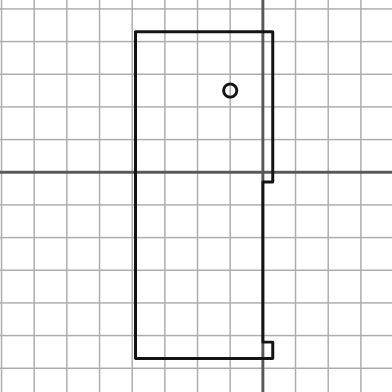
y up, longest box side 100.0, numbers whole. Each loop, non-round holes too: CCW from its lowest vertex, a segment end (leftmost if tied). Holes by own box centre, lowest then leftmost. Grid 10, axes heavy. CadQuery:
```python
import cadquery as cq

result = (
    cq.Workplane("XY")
    .moveTo(-39.0, -57.0)
    .lineTo(3.0, -57.0)
    .lineTo(3.0, -52.0)
    .lineTo(0.0, -52.0)
    .lineTo(0.0, -3.0)
    .lineTo(3.0, -3.0)
    .lineTo(3.0, 43.0)
    .lineTo(-39.0, 43.0)
    .close()
    .moveTo(-10.0, 25.0)
    .circle(2.0)
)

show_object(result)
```